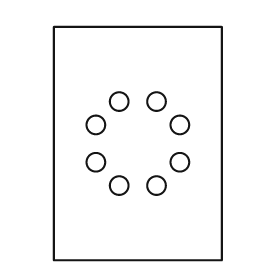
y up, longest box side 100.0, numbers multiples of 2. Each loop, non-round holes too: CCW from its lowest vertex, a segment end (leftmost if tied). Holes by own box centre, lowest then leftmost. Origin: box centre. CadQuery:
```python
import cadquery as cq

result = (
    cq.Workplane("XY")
    .moveTo(-36.0, -50.0)
    .lineTo(36.0, -50.0)
    .lineTo(36.0, 50.0)
    .lineTo(-36.0, 50.0)
    .close()
    .moveTo(-8.0, -18.0)
    .circle(4.0)
    .moveTo(8.0, -18.0)
    .circle(4.0)
    .moveTo(-18.0, -8.0)
    .circle(4.0)
    .moveTo(18.0, -8.0)
    .circle(4.0)
    .moveTo(-18.0, 8.0)
    .circle(4.0)
    .moveTo(18.0, 8.0)
    .circle(4.0)
    .moveTo(-8.0, 18.0)
    .circle(4.0)
    .moveTo(8.0, 18.0)
    .circle(4.0)
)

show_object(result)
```